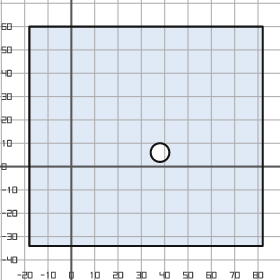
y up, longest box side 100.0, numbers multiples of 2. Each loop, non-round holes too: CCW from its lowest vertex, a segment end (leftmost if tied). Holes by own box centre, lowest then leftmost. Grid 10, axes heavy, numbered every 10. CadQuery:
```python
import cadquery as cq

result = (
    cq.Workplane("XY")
    .moveTo(-18.0, -34.0)
    .lineTo(82.0, -34.0)
    .lineTo(82.0, 60.0)
    .lineTo(-18.0, 60.0)
    .close()
    .moveTo(38.0, 6.0)
    .circle(4.0)
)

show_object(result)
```